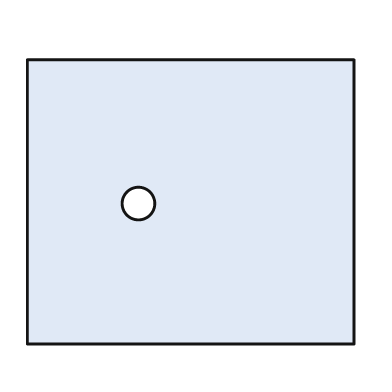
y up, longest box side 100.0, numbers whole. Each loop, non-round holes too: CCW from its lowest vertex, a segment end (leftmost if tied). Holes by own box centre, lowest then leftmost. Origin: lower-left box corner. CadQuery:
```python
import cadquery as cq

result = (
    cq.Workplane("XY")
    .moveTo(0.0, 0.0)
    .lineTo(100.0, 0.0)
    .lineTo(100.0, 87.0)
    .lineTo(0.0, 87.0)
    .close()
    .moveTo(34.0, 43.0)
    .circle(5.0)
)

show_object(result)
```